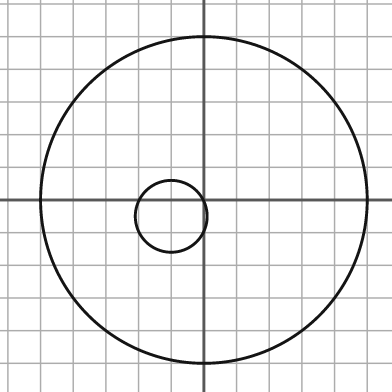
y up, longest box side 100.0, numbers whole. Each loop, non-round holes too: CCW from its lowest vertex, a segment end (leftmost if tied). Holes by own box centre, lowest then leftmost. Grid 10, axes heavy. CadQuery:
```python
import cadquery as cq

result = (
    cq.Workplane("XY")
    .moveTo(0.0, 0.0)
    .circle(50.0)
    .moveTo(-10.0, -5.0)
    .circle(11.0)
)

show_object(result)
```